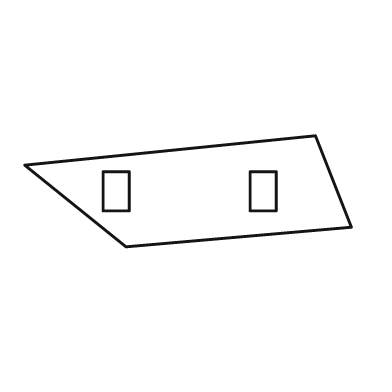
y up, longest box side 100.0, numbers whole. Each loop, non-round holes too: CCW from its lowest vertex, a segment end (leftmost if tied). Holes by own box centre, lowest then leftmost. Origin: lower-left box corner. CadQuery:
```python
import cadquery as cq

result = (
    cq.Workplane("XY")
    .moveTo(31.0, 0.0)
    .lineTo(100.0, 6.0)
    .lineTo(89.0, 34.0)
    .lineTo(0.0, 25.0)
    .close()
    .moveTo(24.0, 11.0)
    .lineTo(32.0, 11.0)
    .lineTo(32.0, 23.0)
    .lineTo(24.0, 23.0)
    .close()
    .moveTo(69.0, 11.0)
    .lineTo(77.0, 11.0)
    .lineTo(77.0, 23.0)
    .lineTo(69.0, 23.0)
    .close()
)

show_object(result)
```